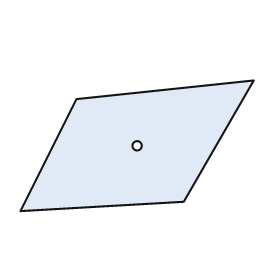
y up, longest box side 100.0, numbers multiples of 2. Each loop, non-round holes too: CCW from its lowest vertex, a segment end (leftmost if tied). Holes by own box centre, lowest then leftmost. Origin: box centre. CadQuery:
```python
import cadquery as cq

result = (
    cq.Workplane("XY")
    .moveTo(-50.0, -28.0)
    .lineTo(20.0, -24.0)
    .lineTo(50.0, 28.0)
    .lineTo(-26.0, 20.0)
    .close()
    .moveTo(0.0, 0.0)
    .circle(2.0)
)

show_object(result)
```